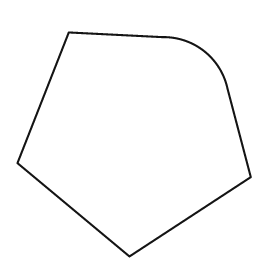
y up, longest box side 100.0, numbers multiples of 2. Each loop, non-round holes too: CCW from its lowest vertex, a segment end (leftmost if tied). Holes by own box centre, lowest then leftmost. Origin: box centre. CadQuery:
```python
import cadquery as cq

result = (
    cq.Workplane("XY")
    .moveTo(-2.0, -48.0)
    .lineTo(50.0, -14.0)
    .lineTo(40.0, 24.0)
    .threePointArc((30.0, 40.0), (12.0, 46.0))
    .lineTo(-28.0, 48.0)
    .lineTo(-50.0, -8.0)
    .close()
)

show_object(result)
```